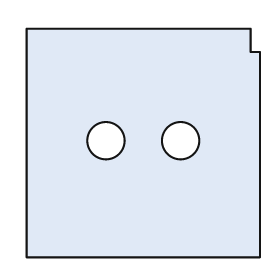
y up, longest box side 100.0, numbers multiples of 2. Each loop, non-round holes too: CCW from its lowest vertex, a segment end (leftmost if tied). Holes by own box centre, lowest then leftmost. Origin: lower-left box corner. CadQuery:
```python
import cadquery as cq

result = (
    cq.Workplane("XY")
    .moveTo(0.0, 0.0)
    .lineTo(100.0, 0.0)
    .lineTo(100.0, 88.0)
    .lineTo(96.0, 88.0)
    .lineTo(96.0, 98.0)
    .lineTo(0.0, 98.0)
    .close()
    .moveTo(34.0, 50.0)
    .circle(8.0)
    .moveTo(66.0, 50.0)
    .circle(8.0)
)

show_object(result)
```